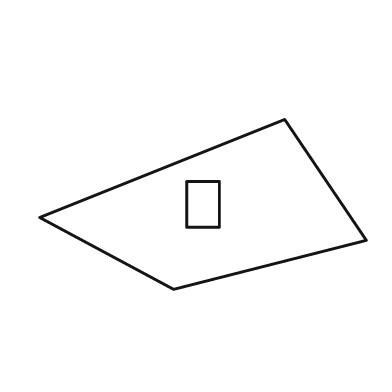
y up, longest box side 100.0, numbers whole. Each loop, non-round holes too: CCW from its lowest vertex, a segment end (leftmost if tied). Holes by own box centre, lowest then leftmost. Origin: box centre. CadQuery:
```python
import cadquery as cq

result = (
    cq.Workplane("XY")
    .moveTo(-9.0, -26.0)
    .lineTo(50.0, -11.0)
    .lineTo(25.0, 26.0)
    .lineTo(-50.0, -4.0)
    .close()
    .moveTo(-5.0, -7.0)
    .lineTo(5.0, -7.0)
    .lineTo(5.0, 7.0)
    .lineTo(-5.0, 7.0)
    .close()
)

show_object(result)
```